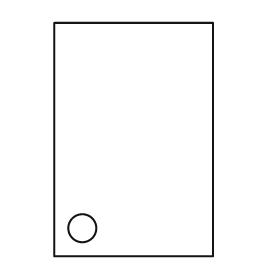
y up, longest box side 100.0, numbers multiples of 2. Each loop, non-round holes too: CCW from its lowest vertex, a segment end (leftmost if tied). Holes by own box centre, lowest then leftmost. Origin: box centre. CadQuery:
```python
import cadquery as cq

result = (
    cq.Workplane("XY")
    .moveTo(-34.0, -50.0)
    .lineTo(34.0, -50.0)
    .lineTo(34.0, 50.0)
    .lineTo(-34.0, 50.0)
    .close()
    .moveTo(-22.0, -38.0)
    .circle(6.0)
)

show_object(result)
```